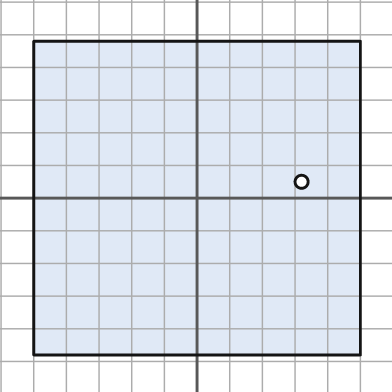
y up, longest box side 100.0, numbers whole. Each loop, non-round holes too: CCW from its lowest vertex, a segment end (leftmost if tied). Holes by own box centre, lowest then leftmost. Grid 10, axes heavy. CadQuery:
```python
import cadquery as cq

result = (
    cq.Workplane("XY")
    .moveTo(-50.0, -48.0)
    .lineTo(50.0, -48.0)
    .lineTo(50.0, 48.0)
    .lineTo(-50.0, 48.0)
    .close()
    .moveTo(32.0, 5.0)
    .circle(2.0)
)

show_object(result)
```